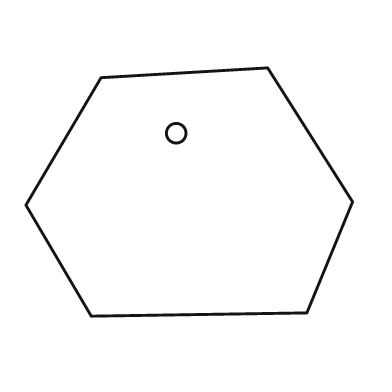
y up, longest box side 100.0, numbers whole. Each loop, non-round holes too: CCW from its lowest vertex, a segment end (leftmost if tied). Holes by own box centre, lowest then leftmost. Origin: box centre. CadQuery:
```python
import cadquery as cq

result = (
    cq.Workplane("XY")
    .moveTo(-30.0, -38.0)
    .lineTo(36.0, -37.0)
    .lineTo(50.0, -3.0)
    .lineTo(24.0, 38.0)
    .lineTo(-27.0, 35.0)
    .lineTo(-50.0, -4.0)
    .close()
    .moveTo(-4.0, 18.0)
    .circle(3.0)
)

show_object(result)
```